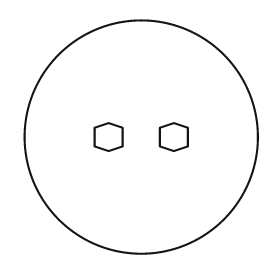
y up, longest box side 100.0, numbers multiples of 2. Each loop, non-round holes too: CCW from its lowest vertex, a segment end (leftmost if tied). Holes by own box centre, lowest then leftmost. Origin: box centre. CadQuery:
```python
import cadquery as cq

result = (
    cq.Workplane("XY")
    .moveTo(0.0, 0.0)
    .circle(50.0)
    .moveTo(-14.0, -6.0)
    .lineTo(-8.0, -4.0)
    .lineTo(-8.0, 4.0)
    .lineTo(-14.0, 6.0)
    .lineTo(-20.0, 4.0)
    .lineTo(-20.0, -4.0)
    .close()
    .moveTo(14.0, -6.0)
    .lineTo(20.0, -4.0)
    .lineTo(20.0, 4.0)
    .lineTo(14.0, 6.0)
    .lineTo(8.0, 4.0)
    .lineTo(8.0, -4.0)
    .close()
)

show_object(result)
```